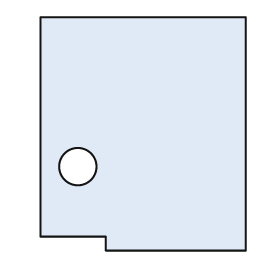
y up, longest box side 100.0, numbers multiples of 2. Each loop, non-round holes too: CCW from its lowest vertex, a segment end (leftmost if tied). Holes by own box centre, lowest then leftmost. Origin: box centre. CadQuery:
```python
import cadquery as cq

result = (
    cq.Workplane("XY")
    .moveTo(-16.0, -50.0)
    .lineTo(44.0, -50.0)
    .lineTo(44.0, 50.0)
    .lineTo(-44.0, 50.0)
    .lineTo(-44.0, -44.0)
    .lineTo(-16.0, -44.0)
    .close()
    .moveTo(-28.0, -14.0)
    .circle(8.0)
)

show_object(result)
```